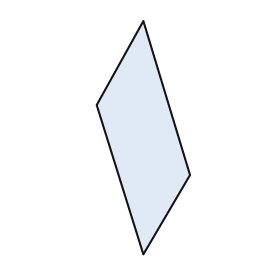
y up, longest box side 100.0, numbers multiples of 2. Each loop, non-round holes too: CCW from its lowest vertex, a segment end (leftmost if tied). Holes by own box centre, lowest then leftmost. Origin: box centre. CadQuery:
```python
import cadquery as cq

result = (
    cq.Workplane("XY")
    .moveTo(0.0, -50.0)
    .lineTo(20.0, -16.0)
    .lineTo(0.0, 50.0)
    .lineTo(-20.0, 14.0)
    .close()
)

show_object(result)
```